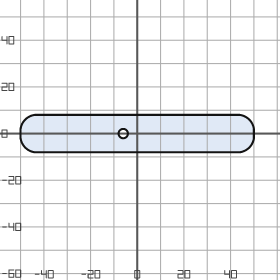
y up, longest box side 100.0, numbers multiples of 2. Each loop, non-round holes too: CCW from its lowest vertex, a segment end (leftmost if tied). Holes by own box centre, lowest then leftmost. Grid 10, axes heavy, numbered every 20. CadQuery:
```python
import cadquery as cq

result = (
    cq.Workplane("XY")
    .moveTo(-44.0, -8.0)
    .lineTo(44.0, -8.0)
    .threePointArc((48.0, -6.0), (50.0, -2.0))
    .lineTo(50.0, 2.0)
    .threePointArc((48.0, 6.0), (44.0, 8.0))
    .lineTo(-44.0, 8.0)
    .threePointArc((-48.0, 6.0), (-50.0, 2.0))
    .lineTo(-50.0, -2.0)
    .threePointArc((-48.0, -6.0), (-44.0, -8.0))
    .close()
    .moveTo(-6.0, 0.0)
    .circle(2.0)
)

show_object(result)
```